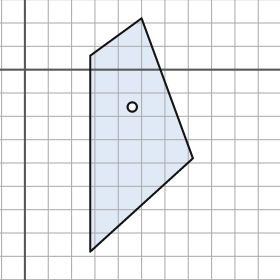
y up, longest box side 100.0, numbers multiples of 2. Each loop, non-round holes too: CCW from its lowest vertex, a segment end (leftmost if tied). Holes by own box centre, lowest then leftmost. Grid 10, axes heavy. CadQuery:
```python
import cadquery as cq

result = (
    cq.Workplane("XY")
    .moveTo(28.0, -78.0)
    .lineTo(72.0, -38.0)
    .lineTo(50.0, 22.0)
    .lineTo(28.0, 6.0)
    .close()
    .moveTo(46.0, -16.0)
    .circle(2.0)
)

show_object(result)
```